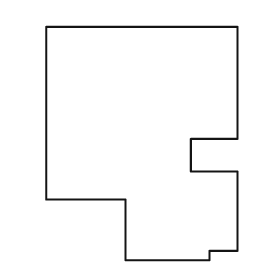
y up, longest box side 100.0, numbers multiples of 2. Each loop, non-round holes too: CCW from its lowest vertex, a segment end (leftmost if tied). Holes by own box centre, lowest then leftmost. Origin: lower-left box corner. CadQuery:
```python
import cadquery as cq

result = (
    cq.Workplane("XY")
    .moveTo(34.0, 0.0)
    .lineTo(70.0, 0.0)
    .lineTo(70.0, 4.0)
    .lineTo(82.0, 4.0)
    .lineTo(82.0, 38.0)
    .lineTo(62.0, 38.0)
    .lineTo(62.0, 52.0)
    .lineTo(82.0, 52.0)
    .lineTo(82.0, 100.0)
    .lineTo(0.0, 100.0)
    .lineTo(0.0, 26.0)
    .lineTo(34.0, 26.0)
    .close()
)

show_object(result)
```